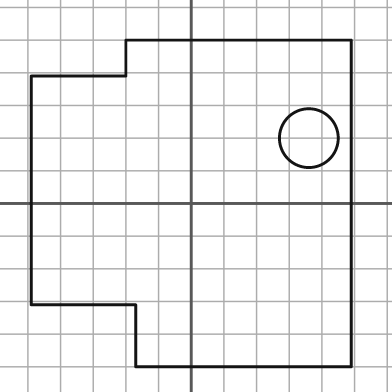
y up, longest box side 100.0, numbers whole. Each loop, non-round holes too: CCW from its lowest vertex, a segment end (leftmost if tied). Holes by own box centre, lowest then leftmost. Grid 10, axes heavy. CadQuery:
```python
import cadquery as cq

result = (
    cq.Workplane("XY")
    .moveTo(-17.0, -50.0)
    .lineTo(49.0, -50.0)
    .lineTo(49.0, 50.0)
    .lineTo(-20.0, 50.0)
    .lineTo(-20.0, 39.0)
    .lineTo(-49.0, 39.0)
    .lineTo(-49.0, -31.0)
    .lineTo(-17.0, -31.0)
    .close()
    .moveTo(36.0, 20.0)
    .circle(9.0)
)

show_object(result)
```